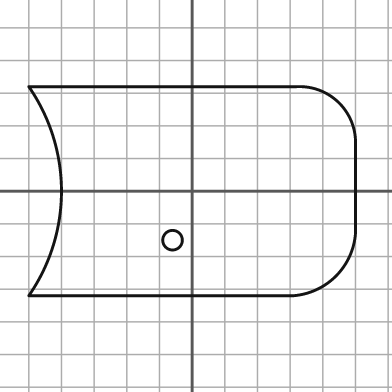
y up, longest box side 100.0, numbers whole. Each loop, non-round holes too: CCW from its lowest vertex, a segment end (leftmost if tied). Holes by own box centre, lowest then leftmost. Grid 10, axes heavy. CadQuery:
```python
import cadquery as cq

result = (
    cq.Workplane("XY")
    .moveTo(-50.0, -32.0)
    .lineTo(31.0, -32.0)
    .threePointArc((44.0, -26.0), (50.0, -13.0))
    .lineTo(50.0, 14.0)
    .threePointArc((45.0, 27.0), (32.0, 32.0))
    .lineTo(-50.0, 32.0)
    .threePointArc((-40.0, 0.0), (-50.0, -32.0))
    .close()
    .moveTo(-6.0, -15.0)
    .circle(3.0)
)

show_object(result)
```